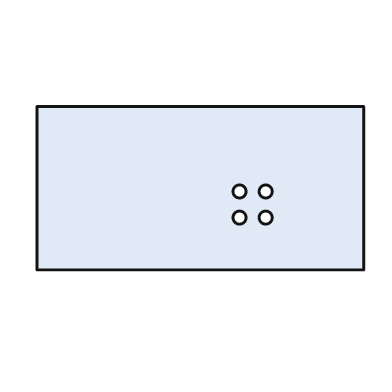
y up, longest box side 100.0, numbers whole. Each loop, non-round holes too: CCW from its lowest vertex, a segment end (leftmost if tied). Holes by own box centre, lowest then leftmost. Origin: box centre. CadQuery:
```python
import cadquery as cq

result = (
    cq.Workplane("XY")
    .moveTo(-50.0, -25.0)
    .lineTo(50.0, -25.0)
    .lineTo(50.0, 25.0)
    .lineTo(-50.0, 25.0)
    .close()
    .moveTo(12.0, -9.0)
    .circle(2.0)
    .moveTo(20.0, -9.0)
    .circle(2.0)
    .moveTo(12.0, -1.0)
    .circle(2.0)
    .moveTo(20.0, -1.0)
    .circle(2.0)
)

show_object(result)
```